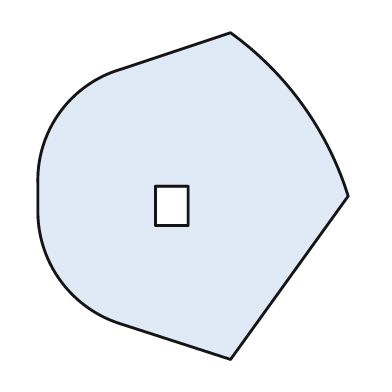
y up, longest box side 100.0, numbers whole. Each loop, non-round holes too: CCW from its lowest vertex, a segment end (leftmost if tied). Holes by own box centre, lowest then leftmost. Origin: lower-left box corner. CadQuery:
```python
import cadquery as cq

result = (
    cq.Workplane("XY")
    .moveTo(59.0, 0.0)
    .lineTo(95.0, 50.0)
    .threePointArc((81.0, 78.0), (59.0, 100.0))
    .lineTo(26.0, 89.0)
    .threePointArc((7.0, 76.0), (0.0, 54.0))
    .lineTo(0.0, 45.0)
    .threePointArc((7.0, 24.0), (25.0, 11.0))
    .close()
    .moveTo(36.0, 41.0)
    .lineTo(46.0, 41.0)
    .lineTo(46.0, 53.0)
    .lineTo(36.0, 53.0)
    .close()
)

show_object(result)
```